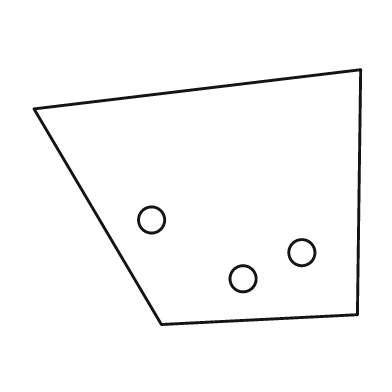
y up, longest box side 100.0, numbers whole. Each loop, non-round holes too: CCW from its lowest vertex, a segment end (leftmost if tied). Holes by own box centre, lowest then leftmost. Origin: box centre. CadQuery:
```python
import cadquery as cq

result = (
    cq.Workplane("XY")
    .moveTo(-11.0, -39.0)
    .lineTo(49.0, -36.0)
    .lineTo(50.0, 39.0)
    .lineTo(-50.0, 27.0)
    .close()
    .moveTo(14.0, -25.0)
    .circle(4.0)
    .moveTo(32.0, -17.0)
    .circle(4.0)
    .moveTo(-14.0, -7.0)
    .circle(4.0)
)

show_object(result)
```